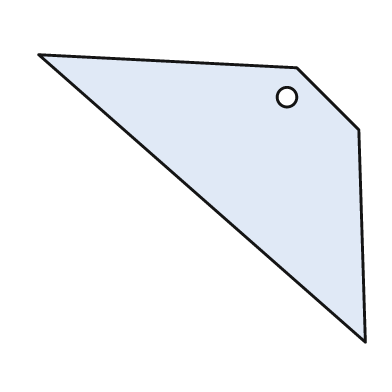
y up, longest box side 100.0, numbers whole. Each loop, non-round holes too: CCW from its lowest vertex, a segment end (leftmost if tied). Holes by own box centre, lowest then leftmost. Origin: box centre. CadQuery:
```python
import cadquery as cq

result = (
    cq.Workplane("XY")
    .moveTo(50.0, -44.0)
    .lineTo(48.0, 21.0)
    .lineTo(29.0, 40.0)
    .lineTo(-50.0, 44.0)
    .close()
    .moveTo(26.0, 31.0)
    .circle(3.0)
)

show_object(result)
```